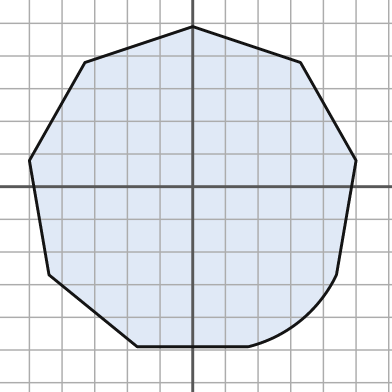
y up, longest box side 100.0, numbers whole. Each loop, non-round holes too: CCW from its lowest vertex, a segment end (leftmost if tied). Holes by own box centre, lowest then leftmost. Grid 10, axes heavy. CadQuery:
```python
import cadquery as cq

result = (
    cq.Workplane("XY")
    .moveTo(-17.0, -49.0)
    .lineTo(17.0, -49.0)
    .threePointArc((33.0, -41.0), (44.0, -27.0))
    .lineTo(50.0, 8.0)
    .lineTo(33.0, 38.0)
    .lineTo(0.0, 49.0)
    .lineTo(-33.0, 38.0)
    .lineTo(-50.0, 8.0)
    .lineTo(-44.0, -27.0)
    .close()
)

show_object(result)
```